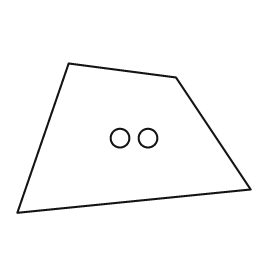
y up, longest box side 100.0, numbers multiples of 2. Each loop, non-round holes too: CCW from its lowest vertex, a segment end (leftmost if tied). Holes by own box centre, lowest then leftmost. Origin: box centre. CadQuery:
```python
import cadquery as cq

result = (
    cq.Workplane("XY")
    .moveTo(-50.0, -32.0)
    .lineTo(50.0, -22.0)
    .lineTo(18.0, 26.0)
    .lineTo(-28.0, 32.0)
    .close()
    .moveTo(-6.0, 0.0)
    .circle(4.0)
    .moveTo(6.0, 0.0)
    .circle(4.0)
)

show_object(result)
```